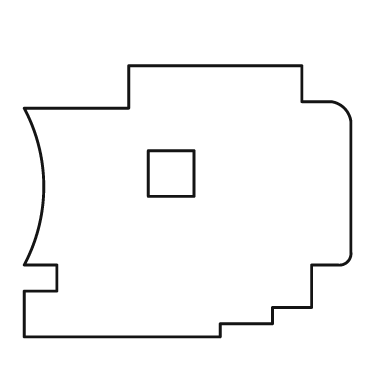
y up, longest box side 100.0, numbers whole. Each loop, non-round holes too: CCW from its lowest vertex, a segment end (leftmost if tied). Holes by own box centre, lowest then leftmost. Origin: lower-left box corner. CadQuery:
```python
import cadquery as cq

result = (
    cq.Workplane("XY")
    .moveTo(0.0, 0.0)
    .lineTo(60.0, 0.0)
    .lineTo(60.0, 4.0)
    .lineTo(76.0, 4.0)
    .lineTo(76.0, 9.0)
    .lineTo(88.0, 9.0)
    .lineTo(88.0, 22.0)
    .lineTo(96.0, 22.0)
    .threePointArc((99.0, 23.0), (100.0, 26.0))
    .lineTo(100.0, 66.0)
    .threePointArc((98.0, 70.0), (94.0, 72.0))
    .lineTo(85.0, 72.0)
    .lineTo(85.0, 83.0)
    .lineTo(32.0, 83.0)
    .lineTo(32.0, 70.0)
    .lineTo(0.0, 70.0)
    .threePointArc((6.0, 46.0), (0.0, 22.0))
    .lineTo(10.0, 22.0)
    .lineTo(10.0, 14.0)
    .lineTo(0.0, 14.0)
    .close()
    .moveTo(38.0, 43.0)
    .lineTo(52.0, 43.0)
    .lineTo(52.0, 57.0)
    .lineTo(38.0, 57.0)
    .close()
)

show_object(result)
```